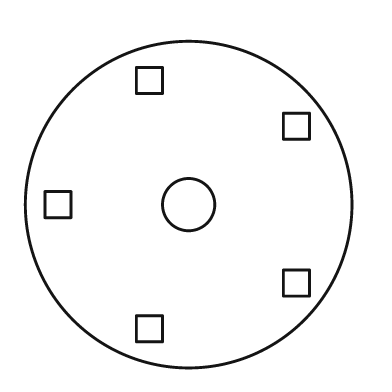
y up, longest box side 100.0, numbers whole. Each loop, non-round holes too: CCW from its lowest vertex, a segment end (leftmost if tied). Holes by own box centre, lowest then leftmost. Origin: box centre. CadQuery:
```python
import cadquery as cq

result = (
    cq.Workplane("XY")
    .moveTo(0.0, 0.0)
    .circle(50.0)
    .moveTo(-16.0, -42.0)
    .lineTo(-8.0, -42.0)
    .lineTo(-8.0, -34.0)
    .lineTo(-16.0, -34.0)
    .close()
    .moveTo(29.0, -28.0)
    .lineTo(37.0, -28.0)
    .lineTo(37.0, -20.0)
    .lineTo(29.0, -20.0)
    .close()
    .moveTo(-44.0, -4.0)
    .lineTo(-36.0, -4.0)
    .lineTo(-36.0, 4.0)
    .lineTo(-44.0, 4.0)
    .close()
    .moveTo(0.0, 0.0)
    .circle(8.0)
    .moveTo(29.0, 20.0)
    .lineTo(37.0, 20.0)
    .lineTo(37.0, 28.0)
    .lineTo(29.0, 28.0)
    .close()
    .moveTo(-16.0, 34.0)
    .lineTo(-8.0, 34.0)
    .lineTo(-8.0, 42.0)
    .lineTo(-16.0, 42.0)
    .close()
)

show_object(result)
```